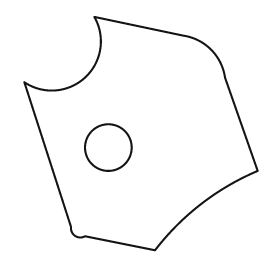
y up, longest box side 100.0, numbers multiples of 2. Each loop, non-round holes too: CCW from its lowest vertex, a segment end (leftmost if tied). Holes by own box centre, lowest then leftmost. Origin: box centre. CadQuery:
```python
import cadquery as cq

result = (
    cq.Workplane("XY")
    .moveTo(6.0, -50.0)
    .threePointArc((26.0, -30.0), (50.0, -16.0))
    .lineTo(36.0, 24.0)
    .threePointArc((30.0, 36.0), (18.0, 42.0))
    .lineTo(-20.0, 50.0)
    .threePointArc((-24.0, 24.0), (-50.0, 22.0))
    .lineTo(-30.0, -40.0)
    .threePointArc((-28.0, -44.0), (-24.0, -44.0))
    .close()
    .moveTo(-14.0, -6.0)
    .circle(10.0)
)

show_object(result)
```